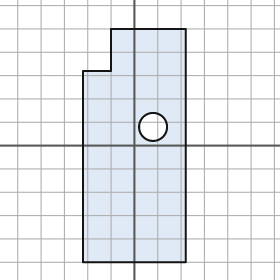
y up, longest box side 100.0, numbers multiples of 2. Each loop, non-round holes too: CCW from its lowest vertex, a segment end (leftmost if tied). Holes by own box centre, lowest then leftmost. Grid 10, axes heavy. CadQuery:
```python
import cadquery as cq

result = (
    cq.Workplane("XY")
    .moveTo(-22.0, -50.0)
    .lineTo(22.0, -50.0)
    .lineTo(22.0, 50.0)
    .lineTo(-10.0, 50.0)
    .lineTo(-10.0, 32.0)
    .lineTo(-22.0, 32.0)
    .close()
    .moveTo(8.0, 8.0)
    .circle(6.0)
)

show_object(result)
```